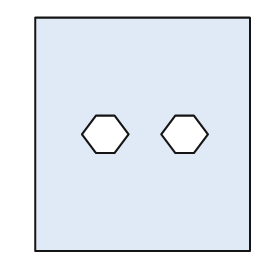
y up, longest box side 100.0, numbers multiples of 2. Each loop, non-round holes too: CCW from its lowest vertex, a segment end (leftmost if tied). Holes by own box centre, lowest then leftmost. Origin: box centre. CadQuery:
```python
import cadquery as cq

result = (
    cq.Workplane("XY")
    .moveTo(-46.0, -50.0)
    .lineTo(46.0, -50.0)
    .lineTo(46.0, 50.0)
    .lineTo(-46.0, 50.0)
    .close()
    .moveTo(-20.0, -8.0)
    .lineTo(-12.0, -8.0)
    .lineTo(-6.0, 0.0)
    .lineTo(-12.0, 8.0)
    .lineTo(-20.0, 8.0)
    .lineTo(-26.0, 0.0)
    .close()
    .moveTo(14.0, -8.0)
    .lineTo(22.0, -8.0)
    .lineTo(28.0, 0.0)
    .lineTo(22.0, 8.0)
    .lineTo(14.0, 8.0)
    .lineTo(8.0, 0.0)
    .close()
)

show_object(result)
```